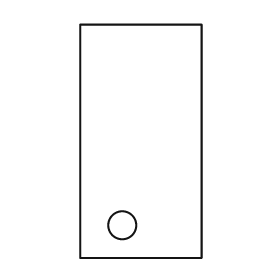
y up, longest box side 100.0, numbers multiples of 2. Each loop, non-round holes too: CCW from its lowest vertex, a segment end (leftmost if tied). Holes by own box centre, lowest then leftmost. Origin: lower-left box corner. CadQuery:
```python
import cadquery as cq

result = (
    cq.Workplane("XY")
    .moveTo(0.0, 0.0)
    .lineTo(52.0, 0.0)
    .lineTo(52.0, 100.0)
    .lineTo(0.0, 100.0)
    .close()
    .moveTo(18.0, 14.0)
    .circle(6.0)
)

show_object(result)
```